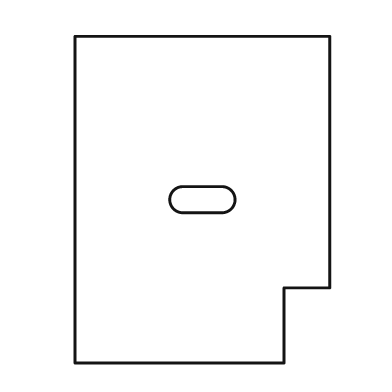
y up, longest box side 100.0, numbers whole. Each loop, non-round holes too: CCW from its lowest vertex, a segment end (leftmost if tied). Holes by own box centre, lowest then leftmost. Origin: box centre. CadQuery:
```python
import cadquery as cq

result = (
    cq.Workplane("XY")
    .moveTo(-39.0, -50.0)
    .lineTo(25.0, -50.0)
    .lineTo(25.0, -27.0)
    .lineTo(39.0, -27.0)
    .lineTo(39.0, 50.0)
    .lineTo(-39.0, 50.0)
    .close()
    .moveTo(-6.0, -4.0)
    .lineTo(6.0, -4.0)
    .threePointArc((10.0, 0.0), (6.0, 4.0))
    .lineTo(-6.0, 4.0)
    .threePointArc((-10.0, 0.0), (-6.0, -4.0))
    .close()
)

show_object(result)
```